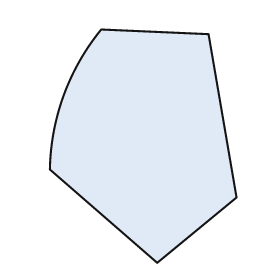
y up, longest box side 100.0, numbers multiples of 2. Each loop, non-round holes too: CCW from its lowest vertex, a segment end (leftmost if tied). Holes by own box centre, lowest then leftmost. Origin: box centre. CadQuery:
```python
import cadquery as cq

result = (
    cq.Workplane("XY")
    .moveTo(6.0, -50.0)
    .lineTo(40.0, -22.0)
    .lineTo(28.0, 48.0)
    .lineTo(-18.0, 50.0)
    .threePointArc((-34.0, 22.0), (-40.0, -10.0))
    .close()
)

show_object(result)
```